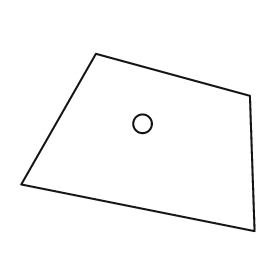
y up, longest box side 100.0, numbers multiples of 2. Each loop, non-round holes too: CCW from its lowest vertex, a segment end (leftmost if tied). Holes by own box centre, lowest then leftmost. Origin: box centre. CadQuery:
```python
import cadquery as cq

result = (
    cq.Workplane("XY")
    .moveTo(50.0, -38.0)
    .lineTo(48.0, 20.0)
    .lineTo(-18.0, 38.0)
    .lineTo(-50.0, -18.0)
    .close()
    .moveTo(2.0, 8.0)
    .circle(4.0)
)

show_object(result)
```